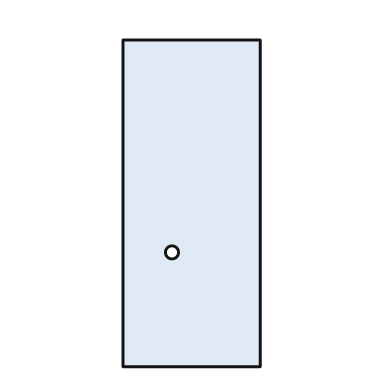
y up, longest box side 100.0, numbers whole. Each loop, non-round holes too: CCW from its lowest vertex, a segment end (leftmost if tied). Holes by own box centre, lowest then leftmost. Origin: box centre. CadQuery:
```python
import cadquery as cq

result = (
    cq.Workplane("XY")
    .moveTo(-21.0, -50.0)
    .lineTo(21.0, -50.0)
    .lineTo(21.0, 50.0)
    .lineTo(-21.0, 50.0)
    .close()
    .moveTo(-6.0, -15.0)
    .circle(2.0)
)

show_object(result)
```